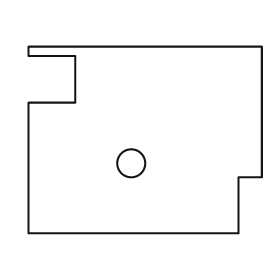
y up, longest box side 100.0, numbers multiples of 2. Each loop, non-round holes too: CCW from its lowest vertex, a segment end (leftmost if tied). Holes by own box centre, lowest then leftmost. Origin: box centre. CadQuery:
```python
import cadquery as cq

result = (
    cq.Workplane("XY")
    .moveTo(-50.0, -40.0)
    .lineTo(40.0, -40.0)
    .lineTo(40.0, -16.0)
    .lineTo(50.0, -16.0)
    .lineTo(50.0, 40.0)
    .lineTo(-50.0, 40.0)
    .lineTo(-50.0, 36.0)
    .lineTo(-30.0, 36.0)
    .lineTo(-30.0, 16.0)
    .lineTo(-50.0, 16.0)
    .close()
    .moveTo(-6.0, -10.0)
    .circle(6.0)
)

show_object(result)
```